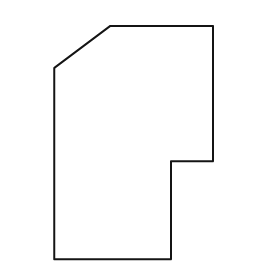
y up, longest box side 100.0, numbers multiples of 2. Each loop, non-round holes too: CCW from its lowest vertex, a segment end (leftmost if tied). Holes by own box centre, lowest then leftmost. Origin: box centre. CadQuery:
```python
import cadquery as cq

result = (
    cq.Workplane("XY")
    .moveTo(-34.0, -50.0)
    .lineTo(16.0, -50.0)
    .lineTo(16.0, -8.0)
    .lineTo(34.0, -8.0)
    .lineTo(34.0, 50.0)
    .lineTo(-10.0, 50.0)
    .lineTo(-34.0, 32.0)
    .close()
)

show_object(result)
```